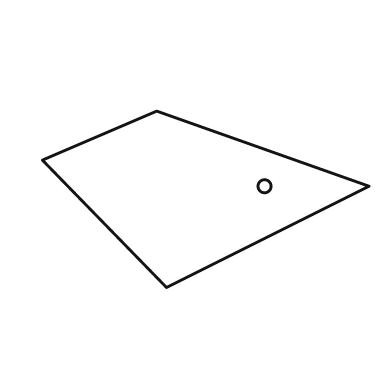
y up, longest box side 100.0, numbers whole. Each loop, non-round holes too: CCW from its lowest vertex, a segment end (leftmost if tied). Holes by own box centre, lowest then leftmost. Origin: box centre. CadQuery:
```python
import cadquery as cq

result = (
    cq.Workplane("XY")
    .moveTo(-12.0, -27.0)
    .lineTo(50.0, 4.0)
    .lineTo(-15.0, 27.0)
    .lineTo(-50.0, 12.0)
    .close()
    .moveTo(18.0, 4.0)
    .circle(2.0)
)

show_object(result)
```